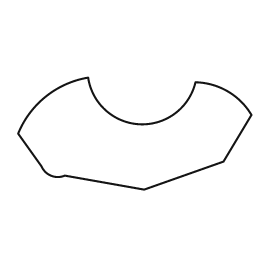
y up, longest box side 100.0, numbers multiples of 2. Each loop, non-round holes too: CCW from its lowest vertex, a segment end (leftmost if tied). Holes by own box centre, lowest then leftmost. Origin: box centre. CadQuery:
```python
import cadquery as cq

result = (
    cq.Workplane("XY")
    .moveTo(4.0, -24.0)
    .lineTo(38.0, -12.0)
    .lineTo(50.0, 8.0)
    .threePointArc((40.0, 18.0), (26.0, 22.0))
    .threePointArc((2.0, 4.0), (-20.0, 24.0))
    .threePointArc((-38.0, 16.0), (-50.0, 0.0))
    .lineTo(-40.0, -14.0)
    .threePointArc((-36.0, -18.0), (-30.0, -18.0))
    .close()
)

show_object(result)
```